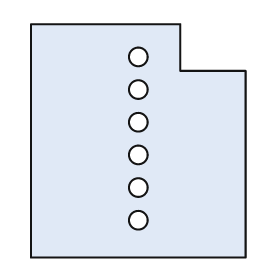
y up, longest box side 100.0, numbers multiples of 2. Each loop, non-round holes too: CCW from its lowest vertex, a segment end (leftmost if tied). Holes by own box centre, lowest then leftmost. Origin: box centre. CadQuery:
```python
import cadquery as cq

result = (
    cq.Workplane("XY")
    .moveTo(-46.0, -50.0)
    .lineTo(46.0, -50.0)
    .lineTo(46.0, 30.0)
    .lineTo(18.0, 30.0)
    .lineTo(18.0, 50.0)
    .lineTo(-46.0, 50.0)
    .close()
    .moveTo(0.0, -34.0)
    .circle(4.0)
    .moveTo(0.0, -20.0)
    .circle(4.0)
    .moveTo(0.0, -6.0)
    .circle(4.0)
    .moveTo(0.0, 8.0)
    .circle(4.0)
    .moveTo(0.0, 22.0)
    .circle(4.0)
    .moveTo(0.0, 36.0)
    .circle(4.0)
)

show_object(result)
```